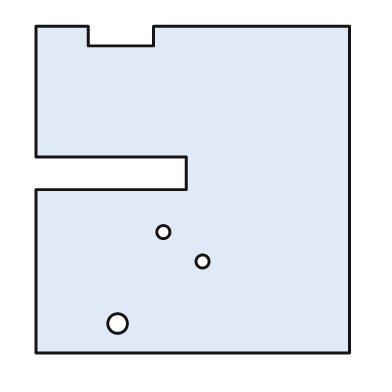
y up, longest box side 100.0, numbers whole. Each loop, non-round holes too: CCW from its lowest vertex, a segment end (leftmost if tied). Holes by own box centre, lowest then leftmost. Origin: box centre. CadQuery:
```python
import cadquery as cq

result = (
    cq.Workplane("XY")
    .moveTo(-48.0, -50.0)
    .lineTo(48.0, -50.0)
    .lineTo(48.0, 50.0)
    .lineTo(-12.0, 50.0)
    .lineTo(-12.0, 44.0)
    .lineTo(-32.0, 44.0)
    .lineTo(-32.0, 50.0)
    .lineTo(-48.0, 50.0)
    .lineTo(-48.0, 10.0)
    .lineTo(-2.0, 10.0)
    .lineTo(-2.0, 0.0)
    .lineTo(-48.0, 0.0)
    .close()
    .moveTo(-23.0, -41.0)
    .circle(3.0)
    .moveTo(3.0, -22.0)
    .circle(2.0)
    .moveTo(-9.0, -13.0)
    .circle(2.0)
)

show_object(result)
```